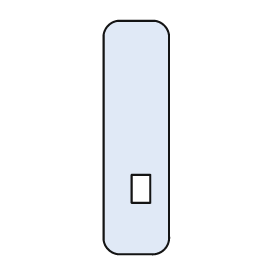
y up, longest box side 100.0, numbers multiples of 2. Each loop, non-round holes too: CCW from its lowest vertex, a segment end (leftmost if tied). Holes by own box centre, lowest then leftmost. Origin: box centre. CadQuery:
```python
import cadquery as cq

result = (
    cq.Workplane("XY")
    .moveTo(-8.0, -50.0)
    .lineTo(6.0, -50.0)
    .threePointArc((12.0, -48.0), (14.0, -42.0))
    .lineTo(14.0, 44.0)
    .threePointArc((12.0, 48.0), (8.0, 50.0))
    .lineTo(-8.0, 50.0)
    .threePointArc((-12.0, 48.0), (-14.0, 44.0))
    .lineTo(-14.0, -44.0)
    .threePointArc((-12.0, -48.0), (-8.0, -50.0))
    .close()
    .moveTo(-2.0, -28.0)
    .lineTo(6.0, -28.0)
    .lineTo(6.0, -16.0)
    .lineTo(-2.0, -16.0)
    .close()
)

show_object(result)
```